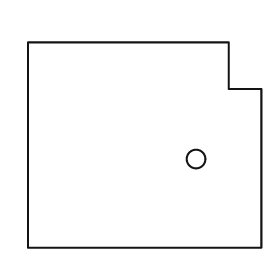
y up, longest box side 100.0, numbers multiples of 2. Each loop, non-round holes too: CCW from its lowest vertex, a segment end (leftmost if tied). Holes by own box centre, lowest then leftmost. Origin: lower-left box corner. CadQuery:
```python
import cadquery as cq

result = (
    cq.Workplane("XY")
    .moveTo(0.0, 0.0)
    .lineTo(100.0, 0.0)
    .lineTo(100.0, 68.0)
    .lineTo(86.0, 68.0)
    .lineTo(86.0, 88.0)
    .lineTo(0.0, 88.0)
    .close()
    .moveTo(72.0, 38.0)
    .circle(4.0)
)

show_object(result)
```